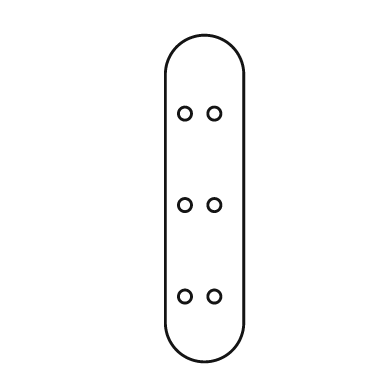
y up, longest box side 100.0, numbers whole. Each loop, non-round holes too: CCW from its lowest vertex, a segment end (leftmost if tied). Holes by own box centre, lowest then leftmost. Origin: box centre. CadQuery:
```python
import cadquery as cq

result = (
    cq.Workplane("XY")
    .moveTo(-12.0, -38.0)
    .threePointArc((0.0, -50.0), (12.0, -38.0))
    .lineTo(12.0, 38.0)
    .threePointArc((0.0, 50.0), (-12.0, 38.0))
    .close()
    .moveTo(-6.0, -30.0)
    .circle(2.0)
    .moveTo(3.0, -30.0)
    .circle(2.0)
    .moveTo(-6.0, -2.0)
    .circle(2.0)
    .moveTo(3.0, -2.0)
    .circle(2.0)
    .moveTo(-6.0, 26.0)
    .circle(2.0)
    .moveTo(3.0, 26.0)
    .circle(2.0)
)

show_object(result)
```